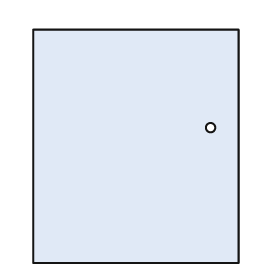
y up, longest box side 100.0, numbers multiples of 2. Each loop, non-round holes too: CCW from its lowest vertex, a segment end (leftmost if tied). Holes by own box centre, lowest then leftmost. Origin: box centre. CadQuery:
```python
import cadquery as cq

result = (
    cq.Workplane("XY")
    .moveTo(-44.0, -50.0)
    .lineTo(44.0, -50.0)
    .lineTo(44.0, 50.0)
    .lineTo(-44.0, 50.0)
    .close()
    .moveTo(32.0, 8.0)
    .circle(2.0)
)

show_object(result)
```